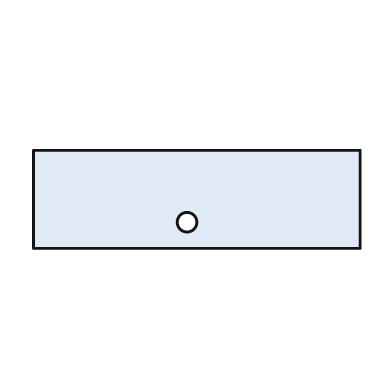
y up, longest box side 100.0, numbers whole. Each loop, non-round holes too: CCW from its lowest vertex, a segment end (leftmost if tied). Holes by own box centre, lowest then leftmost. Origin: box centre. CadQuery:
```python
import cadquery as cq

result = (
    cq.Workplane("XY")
    .moveTo(-50.0, -15.0)
    .lineTo(50.0, -15.0)
    .lineTo(50.0, 15.0)
    .lineTo(-50.0, 15.0)
    .close()
    .moveTo(-3.0, -7.0)
    .circle(3.0)
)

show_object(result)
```